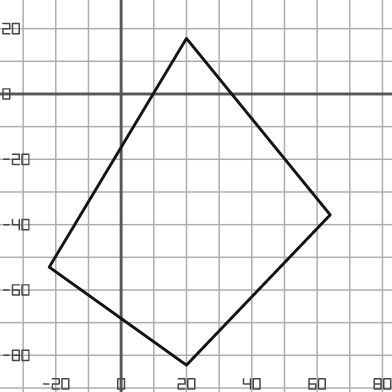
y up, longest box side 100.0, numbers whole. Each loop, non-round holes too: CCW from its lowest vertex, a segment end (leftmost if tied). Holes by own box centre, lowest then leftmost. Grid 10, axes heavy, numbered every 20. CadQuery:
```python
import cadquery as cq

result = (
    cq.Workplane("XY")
    .moveTo(20.0, -83.0)
    .lineTo(64.0, -37.0)
    .lineTo(20.0, 17.0)
    .lineTo(-22.0, -53.0)
    .close()
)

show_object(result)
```